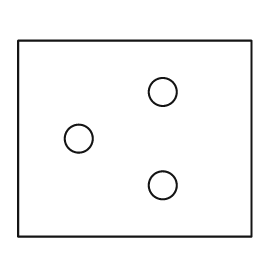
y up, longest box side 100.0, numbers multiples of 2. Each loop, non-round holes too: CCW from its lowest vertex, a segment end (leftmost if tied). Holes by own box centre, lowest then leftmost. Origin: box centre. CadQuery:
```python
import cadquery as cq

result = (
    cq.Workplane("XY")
    .moveTo(-50.0, -42.0)
    .lineTo(50.0, -42.0)
    .lineTo(50.0, 42.0)
    .lineTo(-50.0, 42.0)
    .close()
    .moveTo(12.0, -20.0)
    .circle(6.0)
    .moveTo(-24.0, 0.0)
    .circle(6.0)
    .moveTo(12.0, 20.0)
    .circle(6.0)
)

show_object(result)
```